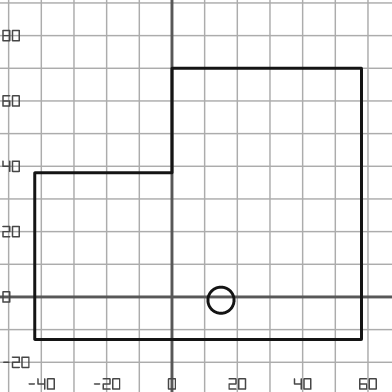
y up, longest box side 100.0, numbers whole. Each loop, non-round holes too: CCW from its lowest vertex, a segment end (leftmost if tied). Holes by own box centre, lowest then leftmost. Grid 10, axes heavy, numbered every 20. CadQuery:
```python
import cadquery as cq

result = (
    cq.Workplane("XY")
    .moveTo(-42.0, -13.0)
    .lineTo(58.0, -13.0)
    .lineTo(58.0, 70.0)
    .lineTo(0.0, 70.0)
    .lineTo(0.0, 38.0)
    .lineTo(-42.0, 38.0)
    .close()
    .moveTo(15.0, -1.0)
    .circle(4.0)
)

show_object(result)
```